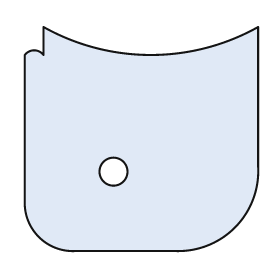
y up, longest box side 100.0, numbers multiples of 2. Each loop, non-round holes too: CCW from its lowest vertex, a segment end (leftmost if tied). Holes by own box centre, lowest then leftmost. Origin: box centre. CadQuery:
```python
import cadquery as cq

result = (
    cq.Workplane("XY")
    .moveTo(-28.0, -48.0)
    .lineTo(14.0, -48.0)
    .threePointArc((40.0, -38.0), (50.0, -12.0))
    .lineTo(50.0, 48.0)
    .threePointArc((4.0, 36.0), (-42.0, 48.0))
    .lineTo(-42.0, 36.0)
    .threePointArc((-46.0, 38.0), (-50.0, 36.0))
    .lineTo(-50.0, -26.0)
    .threePointArc((-44.0, -42.0), (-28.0, -48.0))
    .close()
    .moveTo(-12.0, -14.0)
    .circle(6.0)
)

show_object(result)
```